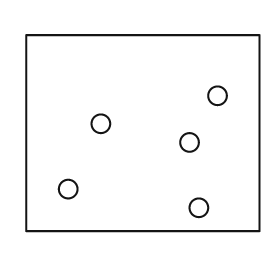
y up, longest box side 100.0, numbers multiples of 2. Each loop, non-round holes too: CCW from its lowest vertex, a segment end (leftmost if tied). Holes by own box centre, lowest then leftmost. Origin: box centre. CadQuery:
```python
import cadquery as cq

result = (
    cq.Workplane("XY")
    .moveTo(-50.0, -42.0)
    .lineTo(50.0, -42.0)
    .lineTo(50.0, 42.0)
    .lineTo(-50.0, 42.0)
    .close()
    .moveTo(24.0, -32.0)
    .circle(4.0)
    .moveTo(-32.0, -24.0)
    .circle(4.0)
    .moveTo(20.0, -4.0)
    .circle(4.0)
    .moveTo(-18.0, 4.0)
    .circle(4.0)
    .moveTo(32.0, 16.0)
    .circle(4.0)
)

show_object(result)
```